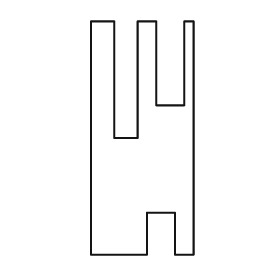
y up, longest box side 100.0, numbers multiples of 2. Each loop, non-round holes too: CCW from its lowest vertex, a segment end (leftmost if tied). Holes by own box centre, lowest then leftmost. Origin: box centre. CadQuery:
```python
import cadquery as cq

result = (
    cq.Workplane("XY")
    .moveTo(-22.0, -50.0)
    .lineTo(2.0, -50.0)
    .lineTo(2.0, -32.0)
    .lineTo(14.0, -32.0)
    .lineTo(14.0, -50.0)
    .lineTo(22.0, -50.0)
    .lineTo(22.0, 50.0)
    .lineTo(18.0, 50.0)
    .lineTo(18.0, 14.0)
    .lineTo(6.0, 14.0)
    .lineTo(6.0, 50.0)
    .lineTo(-2.0, 50.0)
    .lineTo(-2.0, 0.0)
    .lineTo(-12.0, 0.0)
    .lineTo(-12.0, 50.0)
    .lineTo(-22.0, 50.0)
    .close()
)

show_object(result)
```